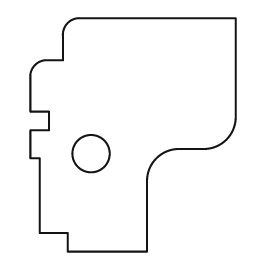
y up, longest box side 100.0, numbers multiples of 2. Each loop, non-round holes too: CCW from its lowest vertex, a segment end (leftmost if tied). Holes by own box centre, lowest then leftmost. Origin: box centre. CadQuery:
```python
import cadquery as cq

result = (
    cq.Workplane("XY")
    .moveTo(-28.0, -50.0)
    .lineTo(6.0, -50.0)
    .lineTo(6.0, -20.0)
    .threePointArc((10.0, -10.0), (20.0, -6.0))
    .lineTo(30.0, -6.0)
    .threePointArc((40.0, -2.0), (44.0, 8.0))
    .lineTo(44.0, 50.0)
    .lineTo(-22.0, 50.0)
    .threePointArc((-28.0, 48.0), (-30.0, 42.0))
    .lineTo(-30.0, 32.0)
    .lineTo(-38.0, 32.0)
    .threePointArc((-42.0, 30.0), (-44.0, 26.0))
    .lineTo(-44.0, 10.0)
    .lineTo(-36.0, 10.0)
    .lineTo(-36.0, 2.0)
    .lineTo(-44.0, 2.0)
    .lineTo(-44.0, -10.0)
    .lineTo(-40.0, -10.0)
    .lineTo(-40.0, -42.0)
    .lineTo(-28.0, -42.0)
    .close()
    .moveTo(-18.0, -8.0)
    .circle(8.0)
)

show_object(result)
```